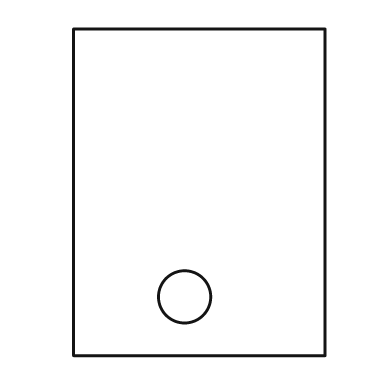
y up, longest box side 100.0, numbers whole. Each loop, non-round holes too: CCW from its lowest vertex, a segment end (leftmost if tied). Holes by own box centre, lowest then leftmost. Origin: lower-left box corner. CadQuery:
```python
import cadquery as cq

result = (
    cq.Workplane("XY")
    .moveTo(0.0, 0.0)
    .lineTo(77.0, 0.0)
    .lineTo(77.0, 100.0)
    .lineTo(0.0, 100.0)
    .close()
    .moveTo(34.0, 18.0)
    .circle(8.0)
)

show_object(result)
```